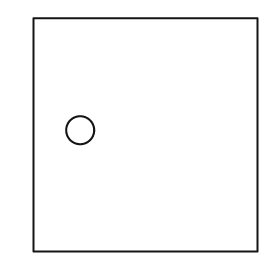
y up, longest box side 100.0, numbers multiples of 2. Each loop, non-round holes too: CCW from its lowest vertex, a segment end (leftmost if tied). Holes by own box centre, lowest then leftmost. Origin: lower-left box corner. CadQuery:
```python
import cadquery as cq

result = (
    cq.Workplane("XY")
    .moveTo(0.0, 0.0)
    .lineTo(96.0, 0.0)
    .lineTo(96.0, 100.0)
    .lineTo(0.0, 100.0)
    .close()
    .moveTo(20.0, 52.0)
    .circle(6.0)
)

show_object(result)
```